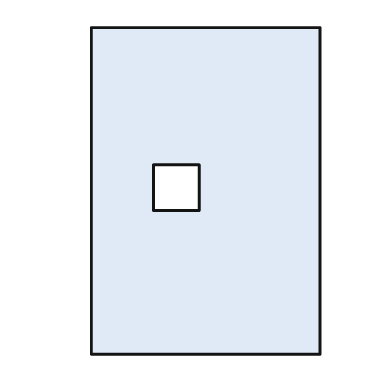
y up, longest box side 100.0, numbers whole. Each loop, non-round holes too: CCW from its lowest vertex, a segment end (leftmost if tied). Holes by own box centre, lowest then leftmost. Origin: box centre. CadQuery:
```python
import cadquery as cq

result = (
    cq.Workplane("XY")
    .moveTo(-35.0, -50.0)
    .lineTo(35.0, -50.0)
    .lineTo(35.0, 50.0)
    .lineTo(-35.0, 50.0)
    .close()
    .moveTo(-16.0, -6.0)
    .lineTo(-2.0, -6.0)
    .lineTo(-2.0, 8.0)
    .lineTo(-16.0, 8.0)
    .close()
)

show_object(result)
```